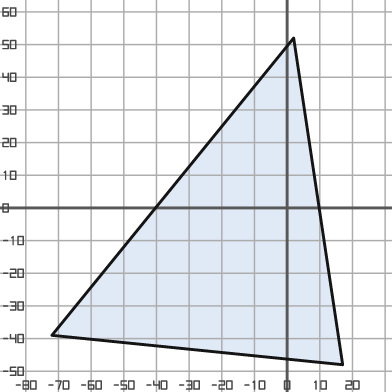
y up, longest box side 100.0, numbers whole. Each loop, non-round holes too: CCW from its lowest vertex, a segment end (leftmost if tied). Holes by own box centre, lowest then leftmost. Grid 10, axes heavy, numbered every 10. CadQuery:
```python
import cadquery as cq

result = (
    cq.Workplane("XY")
    .moveTo(17.0, -48.0)
    .lineTo(2.0, 52.0)
    .lineTo(-72.0, -39.0)
    .close()
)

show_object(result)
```